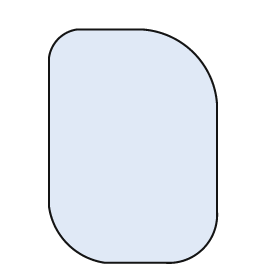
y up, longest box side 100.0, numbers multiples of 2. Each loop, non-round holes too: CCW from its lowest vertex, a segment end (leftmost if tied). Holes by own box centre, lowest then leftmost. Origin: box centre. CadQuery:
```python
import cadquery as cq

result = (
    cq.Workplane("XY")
    .moveTo(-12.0, -50.0)
    .lineTo(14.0, -50.0)
    .threePointArc((30.0, -44.0), (36.0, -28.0))
    .lineTo(36.0, 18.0)
    .threePointArc((26.0, 40.0), (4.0, 50.0))
    .lineTo(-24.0, 50.0)
    .threePointArc((-32.0, 46.0), (-36.0, 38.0))
    .lineTo(-36.0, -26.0)
    .threePointArc((-28.0, -42.0), (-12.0, -50.0))
    .close()
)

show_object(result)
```